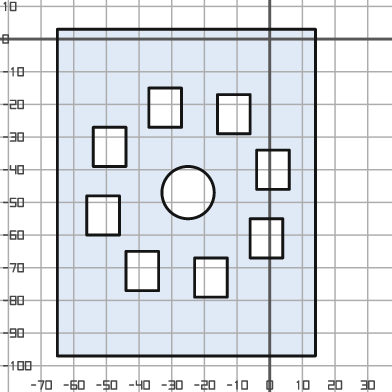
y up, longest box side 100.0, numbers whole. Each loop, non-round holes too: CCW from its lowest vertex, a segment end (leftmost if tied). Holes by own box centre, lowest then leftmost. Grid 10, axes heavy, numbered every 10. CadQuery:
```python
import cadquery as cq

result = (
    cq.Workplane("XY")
    .moveTo(-65.0, -97.0)
    .lineTo(14.0, -97.0)
    .lineTo(14.0, 3.0)
    .lineTo(-65.0, 3.0)
    .close()
    .moveTo(-23.0, -79.0)
    .lineTo(-13.0, -79.0)
    .lineTo(-13.0, -67.0)
    .lineTo(-23.0, -67.0)
    .close()
    .moveTo(-44.0, -77.0)
    .lineTo(-34.0, -77.0)
    .lineTo(-34.0, -65.0)
    .lineTo(-44.0, -65.0)
    .close()
    .moveTo(-6.0, -67.0)
    .lineTo(4.0, -67.0)
    .lineTo(4.0, -55.0)
    .lineTo(-6.0, -55.0)
    .close()
    .moveTo(-56.0, -60.0)
    .lineTo(-46.0, -60.0)
    .lineTo(-46.0, -48.0)
    .lineTo(-56.0, -48.0)
    .close()
    .moveTo(-25.0, -47.0)
    .circle(8.0)
    .moveTo(-4.0, -46.0)
    .lineTo(6.0, -46.0)
    .lineTo(6.0, -34.0)
    .lineTo(-4.0, -34.0)
    .close()
    .moveTo(-54.0, -39.0)
    .lineTo(-44.0, -39.0)
    .lineTo(-44.0, -27.0)
    .lineTo(-54.0, -27.0)
    .close()
    .moveTo(-16.0, -29.0)
    .lineTo(-6.0, -29.0)
    .lineTo(-6.0, -17.0)
    .lineTo(-16.0, -17.0)
    .close()
    .moveTo(-37.0, -27.0)
    .lineTo(-27.0, -27.0)
    .lineTo(-27.0, -15.0)
    .lineTo(-37.0, -15.0)
    .close()
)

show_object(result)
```